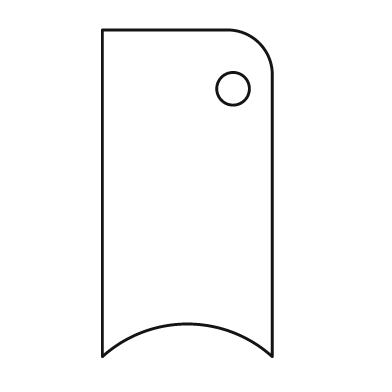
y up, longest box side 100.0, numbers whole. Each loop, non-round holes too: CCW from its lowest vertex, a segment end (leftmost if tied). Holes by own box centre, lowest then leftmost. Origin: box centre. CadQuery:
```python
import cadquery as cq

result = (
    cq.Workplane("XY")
    .moveTo(-26.0, -50.0)
    .threePointArc((0.0, -40.0), (26.0, -50.0))
    .lineTo(26.0, 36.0)
    .threePointArc((22.0, 46.0), (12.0, 50.0))
    .lineTo(-26.0, 50.0)
    .close()
    .moveTo(14.0, 32.0)
    .circle(5.0)
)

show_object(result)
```